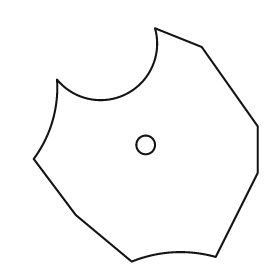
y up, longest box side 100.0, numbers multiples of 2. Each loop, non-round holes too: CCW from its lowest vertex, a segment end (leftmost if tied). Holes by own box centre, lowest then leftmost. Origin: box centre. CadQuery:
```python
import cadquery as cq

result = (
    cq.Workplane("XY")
    .moveTo(-6.0, -50.0)
    .threePointArc((12.0, -46.0), (30.0, -48.0))
    .lineTo(48.0, -12.0)
    .lineTo(48.0, 8.0)
    .lineTo(24.0, 42.0)
    .lineTo(4.0, 50.0)
    .threePointArc((-8.0, 22.0), (-38.0, 28.0))
    .threePointArc((-40.0, 10.0), (-48.0, -6.0))
    .lineTo(-30.0, -30.0)
    .close()
    .moveTo(0.0, 0.0)
    .circle(4.0)
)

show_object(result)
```